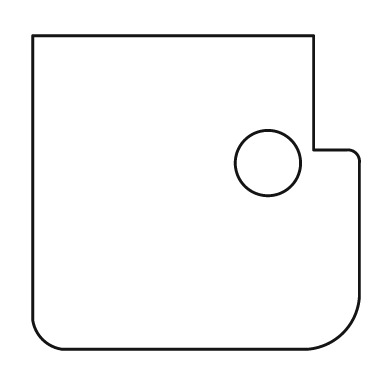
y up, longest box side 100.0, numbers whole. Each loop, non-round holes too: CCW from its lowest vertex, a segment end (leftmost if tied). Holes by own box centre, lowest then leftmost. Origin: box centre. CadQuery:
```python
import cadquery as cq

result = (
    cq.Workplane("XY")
    .moveTo(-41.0, -48.0)
    .lineTo(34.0, -48.0)
    .threePointArc((45.0, -43.0), (50.0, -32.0))
    .lineTo(50.0, 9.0)
    .threePointArc((49.0, 12.0), (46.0, 13.0))
    .lineTo(36.0, 13.0)
    .lineTo(36.0, 48.0)
    .lineTo(-50.0, 48.0)
    .lineTo(-50.0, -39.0)
    .threePointArc((-47.0, -45.0), (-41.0, -48.0))
    .close()
    .moveTo(22.0, 9.0)
    .circle(10.0)
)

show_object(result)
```